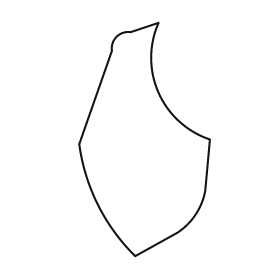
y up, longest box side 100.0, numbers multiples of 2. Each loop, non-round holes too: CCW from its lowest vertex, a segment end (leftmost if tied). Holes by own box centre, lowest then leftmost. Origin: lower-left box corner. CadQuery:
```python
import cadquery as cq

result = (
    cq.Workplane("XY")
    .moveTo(24.0, 0.0)
    .lineTo(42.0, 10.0)
    .threePointArc((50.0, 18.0), (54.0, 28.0))
    .lineTo(56.0, 50.0)
    .threePointArc((34.0, 70.0), (34.0, 100.0))
    .lineTo(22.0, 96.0)
    .threePointArc((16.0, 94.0), (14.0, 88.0))
    .lineTo(0.0, 48.0)
    .threePointArc((8.0, 22.0), (24.0, 0.0))
    .close()
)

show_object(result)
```